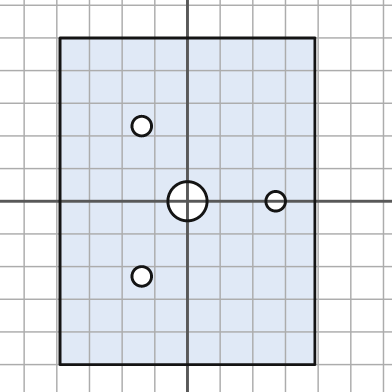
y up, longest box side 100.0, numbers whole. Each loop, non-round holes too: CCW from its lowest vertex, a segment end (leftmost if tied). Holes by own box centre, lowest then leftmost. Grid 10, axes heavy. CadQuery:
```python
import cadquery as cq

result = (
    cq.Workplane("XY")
    .moveTo(-39.0, -50.0)
    .lineTo(39.0, -50.0)
    .lineTo(39.0, 50.0)
    .lineTo(-39.0, 50.0)
    .close()
    .moveTo(-14.0, -23.0)
    .circle(3.0)
    .moveTo(0.0, 0.0)
    .circle(6.0)
    .moveTo(27.0, 0.0)
    .circle(3.0)
    .moveTo(-14.0, 23.0)
    .circle(3.0)
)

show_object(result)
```